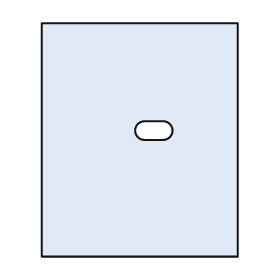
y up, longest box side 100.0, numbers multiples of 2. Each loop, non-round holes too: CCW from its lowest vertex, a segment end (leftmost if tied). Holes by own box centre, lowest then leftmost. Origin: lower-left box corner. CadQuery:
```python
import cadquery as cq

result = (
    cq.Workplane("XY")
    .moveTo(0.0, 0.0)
    .lineTo(84.0, 0.0)
    .lineTo(84.0, 100.0)
    .lineTo(0.0, 100.0)
    .close()
    .moveTo(44.0, 50.0)
    .lineTo(52.0, 50.0)
    .threePointArc((56.0, 54.0), (52.0, 58.0))
    .lineTo(44.0, 58.0)
    .threePointArc((40.0, 54.0), (44.0, 50.0))
    .close()
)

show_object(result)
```